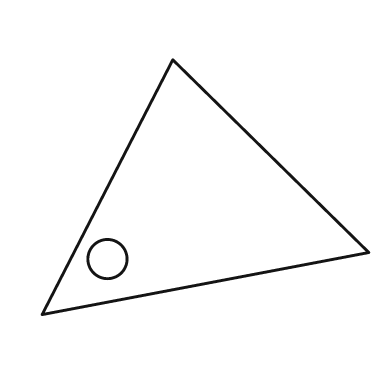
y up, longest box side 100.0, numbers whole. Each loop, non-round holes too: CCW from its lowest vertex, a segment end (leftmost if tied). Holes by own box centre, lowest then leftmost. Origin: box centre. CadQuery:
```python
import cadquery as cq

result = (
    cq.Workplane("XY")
    .moveTo(-50.0, -39.0)
    .lineTo(50.0, -20.0)
    .lineTo(-10.0, 39.0)
    .close()
    .moveTo(-30.0, -22.0)
    .circle(6.0)
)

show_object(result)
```